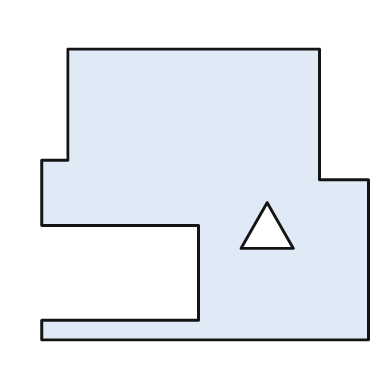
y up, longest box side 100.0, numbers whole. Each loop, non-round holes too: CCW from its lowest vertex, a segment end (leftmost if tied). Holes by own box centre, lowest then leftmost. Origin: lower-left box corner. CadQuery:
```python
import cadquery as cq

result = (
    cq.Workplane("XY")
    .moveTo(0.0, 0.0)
    .lineTo(100.0, 0.0)
    .lineTo(100.0, 49.0)
    .lineTo(85.0, 49.0)
    .lineTo(85.0, 89.0)
    .lineTo(8.0, 89.0)
    .lineTo(8.0, 55.0)
    .lineTo(0.0, 55.0)
    .lineTo(0.0, 35.0)
    .lineTo(48.0, 35.0)
    .lineTo(48.0, 6.0)
    .lineTo(0.0, 6.0)
    .close()
    .moveTo(61.0, 28.0)
    .lineTo(77.0, 28.0)
    .lineTo(69.0, 42.0)
    .close()
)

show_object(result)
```